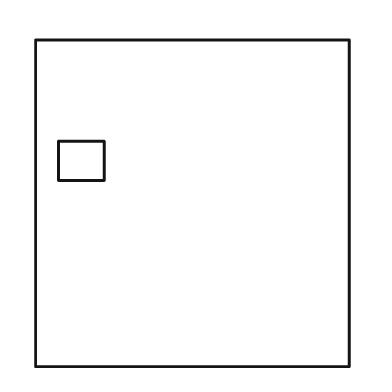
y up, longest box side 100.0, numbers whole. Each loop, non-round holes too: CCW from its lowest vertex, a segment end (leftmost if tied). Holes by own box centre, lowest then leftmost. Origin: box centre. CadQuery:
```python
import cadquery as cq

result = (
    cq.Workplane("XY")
    .moveTo(-48.0, -50.0)
    .lineTo(48.0, -50.0)
    .lineTo(48.0, 50.0)
    .lineTo(-48.0, 50.0)
    .close()
    .moveTo(-41.0, 7.0)
    .lineTo(-27.0, 7.0)
    .lineTo(-27.0, 19.0)
    .lineTo(-41.0, 19.0)
    .close()
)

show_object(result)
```